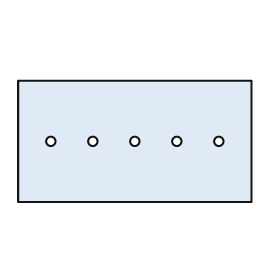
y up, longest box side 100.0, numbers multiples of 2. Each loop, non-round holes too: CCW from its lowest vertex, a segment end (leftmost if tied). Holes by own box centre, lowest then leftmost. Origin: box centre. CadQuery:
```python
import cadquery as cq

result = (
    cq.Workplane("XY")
    .moveTo(-50.0, -26.0)
    .lineTo(50.0, -26.0)
    .lineTo(50.0, 26.0)
    .lineTo(-50.0, 26.0)
    .close()
    .moveTo(-36.0, 0.0)
    .circle(2.0)
    .moveTo(-18.0, 0.0)
    .circle(2.0)
    .moveTo(0.0, 0.0)
    .circle(2.0)
    .moveTo(18.0, 0.0)
    .circle(2.0)
    .moveTo(36.0, 0.0)
    .circle(2.0)
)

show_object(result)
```